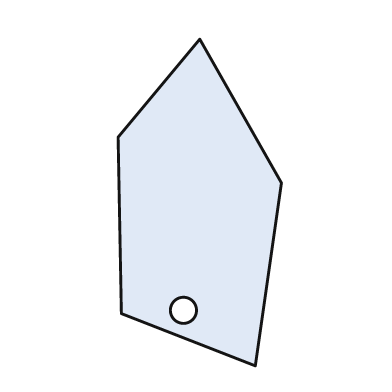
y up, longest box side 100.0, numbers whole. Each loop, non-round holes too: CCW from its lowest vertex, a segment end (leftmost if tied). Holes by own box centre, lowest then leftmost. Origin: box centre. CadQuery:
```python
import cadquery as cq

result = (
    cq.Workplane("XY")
    .moveTo(17.0, -50.0)
    .lineTo(25.0, 6.0)
    .lineTo(0.0, 50.0)
    .lineTo(-25.0, 20.0)
    .lineTo(-24.0, -34.0)
    .close()
    .moveTo(-5.0, -33.0)
    .circle(4.0)
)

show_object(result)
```